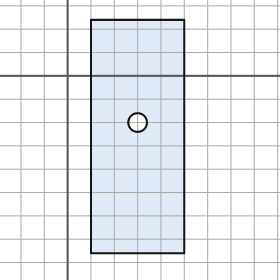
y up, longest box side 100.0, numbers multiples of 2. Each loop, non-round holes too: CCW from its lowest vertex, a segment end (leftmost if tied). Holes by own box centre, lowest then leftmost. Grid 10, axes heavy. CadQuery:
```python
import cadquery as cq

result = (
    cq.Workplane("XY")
    .moveTo(10.0, -76.0)
    .lineTo(50.0, -76.0)
    .lineTo(50.0, 24.0)
    .lineTo(10.0, 24.0)
    .close()
    .moveTo(30.0, -20.0)
    .circle(4.0)
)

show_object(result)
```